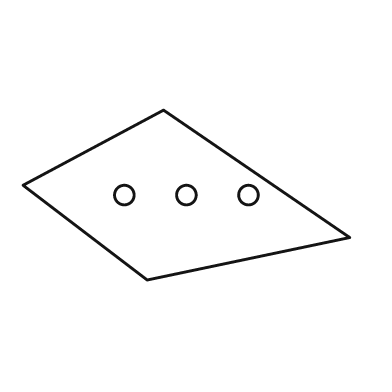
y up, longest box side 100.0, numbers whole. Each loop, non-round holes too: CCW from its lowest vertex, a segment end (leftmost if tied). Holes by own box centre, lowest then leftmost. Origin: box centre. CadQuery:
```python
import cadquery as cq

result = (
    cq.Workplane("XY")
    .moveTo(-12.0, -26.0)
    .lineTo(50.0, -13.0)
    .lineTo(-7.0, 26.0)
    .lineTo(-50.0, 3.0)
    .close()
    .moveTo(-19.0, 0.0)
    .circle(3.0)
    .moveTo(0.0, 0.0)
    .circle(3.0)
    .moveTo(19.0, 0.0)
    .circle(3.0)
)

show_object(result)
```